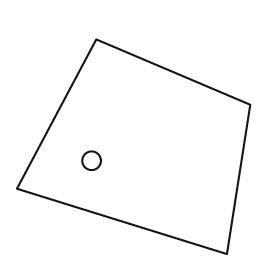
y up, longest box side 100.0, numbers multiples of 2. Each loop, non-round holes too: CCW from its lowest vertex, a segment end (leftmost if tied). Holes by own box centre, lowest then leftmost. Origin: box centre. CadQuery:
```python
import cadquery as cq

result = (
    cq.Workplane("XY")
    .moveTo(40.0, -46.0)
    .lineTo(50.0, 18.0)
    .lineTo(-16.0, 46.0)
    .lineTo(-50.0, -18.0)
    .close()
    .moveTo(-18.0, -6.0)
    .circle(4.0)
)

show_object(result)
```